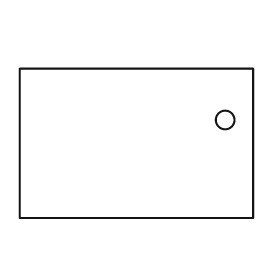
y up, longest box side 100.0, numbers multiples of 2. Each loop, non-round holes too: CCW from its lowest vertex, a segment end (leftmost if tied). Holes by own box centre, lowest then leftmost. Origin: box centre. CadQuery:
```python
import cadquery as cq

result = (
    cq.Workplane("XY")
    .moveTo(-50.0, -32.0)
    .lineTo(50.0, -32.0)
    .lineTo(50.0, 32.0)
    .lineTo(-50.0, 32.0)
    .close()
    .moveTo(38.0, 10.0)
    .circle(4.0)
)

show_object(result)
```